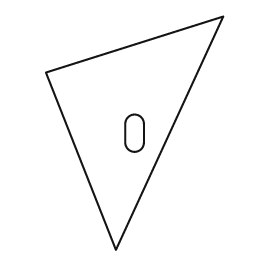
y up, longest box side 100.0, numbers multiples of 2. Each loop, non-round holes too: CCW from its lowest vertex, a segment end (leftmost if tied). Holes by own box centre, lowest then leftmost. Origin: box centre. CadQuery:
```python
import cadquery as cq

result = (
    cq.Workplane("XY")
    .moveTo(-8.0, -50.0)
    .lineTo(38.0, 50.0)
    .lineTo(-38.0, 26.0)
    .close()
    .moveTo(-4.0, -4.0)
    .threePointArc((0.0, -8.0), (4.0, -4.0))
    .lineTo(4.0, 4.0)
    .threePointArc((0.0, 8.0), (-4.0, 4.0))
    .close()
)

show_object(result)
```